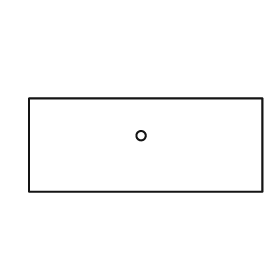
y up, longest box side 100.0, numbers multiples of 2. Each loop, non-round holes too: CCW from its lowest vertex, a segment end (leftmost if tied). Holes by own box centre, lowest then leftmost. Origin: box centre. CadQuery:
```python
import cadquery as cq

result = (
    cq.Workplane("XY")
    .moveTo(-50.0, -20.0)
    .lineTo(50.0, -20.0)
    .lineTo(50.0, 20.0)
    .lineTo(-50.0, 20.0)
    .close()
    .moveTo(-2.0, 4.0)
    .circle(2.0)
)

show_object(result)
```